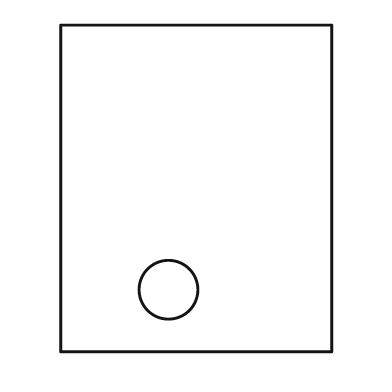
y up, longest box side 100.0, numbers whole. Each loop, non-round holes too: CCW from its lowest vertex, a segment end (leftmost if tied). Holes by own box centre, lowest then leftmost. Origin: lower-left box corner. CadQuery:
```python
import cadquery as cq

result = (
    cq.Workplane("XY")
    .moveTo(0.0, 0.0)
    .lineTo(83.0, 0.0)
    .lineTo(83.0, 100.0)
    .lineTo(0.0, 100.0)
    .close()
    .moveTo(33.0, 19.0)
    .circle(9.0)
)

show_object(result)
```